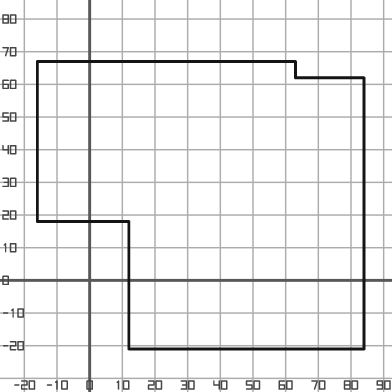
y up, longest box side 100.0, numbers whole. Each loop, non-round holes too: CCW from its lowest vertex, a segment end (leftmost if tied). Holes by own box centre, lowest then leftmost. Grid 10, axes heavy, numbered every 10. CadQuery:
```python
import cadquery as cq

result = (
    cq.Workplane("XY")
    .moveTo(12.0, -21.0)
    .lineTo(84.0, -21.0)
    .lineTo(84.0, 62.0)
    .lineTo(63.0, 62.0)
    .lineTo(63.0, 67.0)
    .lineTo(-16.0, 67.0)
    .lineTo(-16.0, 18.0)
    .lineTo(12.0, 18.0)
    .close()
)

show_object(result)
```